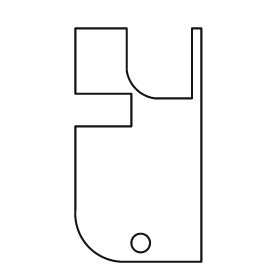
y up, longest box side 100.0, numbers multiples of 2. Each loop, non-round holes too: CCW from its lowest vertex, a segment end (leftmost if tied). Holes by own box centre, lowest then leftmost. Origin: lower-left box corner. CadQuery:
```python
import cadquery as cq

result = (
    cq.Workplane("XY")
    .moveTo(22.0, 0.0)
    .lineTo(54.0, 0.0)
    .lineTo(54.0, 100.0)
    .lineTo(50.0, 100.0)
    .lineTo(50.0, 70.0)
    .lineTo(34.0, 70.0)
    .threePointArc((26.0, 74.0), (22.0, 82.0))
    .lineTo(22.0, 100.0)
    .lineTo(0.0, 100.0)
    .lineTo(0.0, 72.0)
    .lineTo(24.0, 72.0)
    .lineTo(24.0, 58.0)
    .lineTo(0.0, 58.0)
    .lineTo(0.0, 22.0)
    .threePointArc((6.0, 6.0), (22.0, 0.0))
    .close()
    .moveTo(28.0, 8.0)
    .circle(4.0)
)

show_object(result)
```